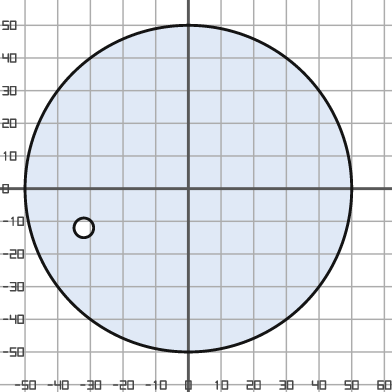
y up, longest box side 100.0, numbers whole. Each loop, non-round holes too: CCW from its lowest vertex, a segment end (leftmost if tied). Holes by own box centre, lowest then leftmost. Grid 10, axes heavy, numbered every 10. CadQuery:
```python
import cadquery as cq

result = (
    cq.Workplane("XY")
    .moveTo(0.0, 0.0)
    .circle(50.0)
    .moveTo(-32.0, -12.0)
    .circle(3.0)
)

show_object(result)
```